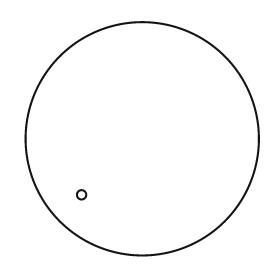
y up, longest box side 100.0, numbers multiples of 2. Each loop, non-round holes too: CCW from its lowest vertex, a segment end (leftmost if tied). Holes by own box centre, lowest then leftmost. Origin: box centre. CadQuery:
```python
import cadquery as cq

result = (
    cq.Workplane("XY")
    .moveTo(0.0, 0.0)
    .circle(50.0)
    .moveTo(-26.0, -24.0)
    .circle(2.0)
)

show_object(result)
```